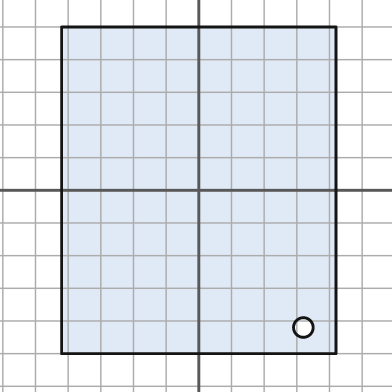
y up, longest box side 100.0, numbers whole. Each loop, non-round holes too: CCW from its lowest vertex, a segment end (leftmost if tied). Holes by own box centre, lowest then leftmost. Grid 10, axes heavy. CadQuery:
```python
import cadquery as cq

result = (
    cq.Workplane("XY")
    .moveTo(-42.0, -50.0)
    .lineTo(42.0, -50.0)
    .lineTo(42.0, 50.0)
    .lineTo(-42.0, 50.0)
    .close()
    .moveTo(32.0, -42.0)
    .circle(3.0)
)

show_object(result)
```